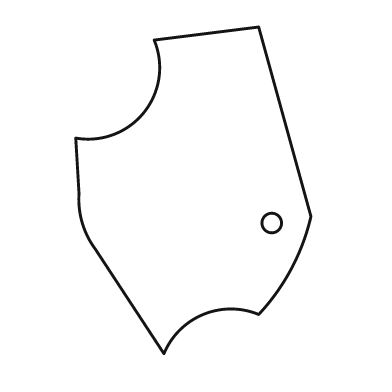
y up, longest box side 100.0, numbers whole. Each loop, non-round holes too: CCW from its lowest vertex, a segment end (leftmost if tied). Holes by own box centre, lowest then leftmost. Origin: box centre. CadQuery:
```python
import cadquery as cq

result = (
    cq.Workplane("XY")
    .moveTo(-9.0, -50.0)
    .threePointArc((3.0, -38.0), (20.0, -38.0))
    .threePointArc((30.0, -24.0), (36.0, -8.0))
    .lineTo(20.0, 50.0)
    .lineTo(-12.0, 46.0)
    .threePointArc((-15.0, 24.0), (-36.0, 16.0))
    .lineTo(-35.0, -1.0)
    .threePointArc((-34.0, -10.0), (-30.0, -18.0))
    .close()
    .moveTo(24.0, -10.0)
    .circle(3.0)
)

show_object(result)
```